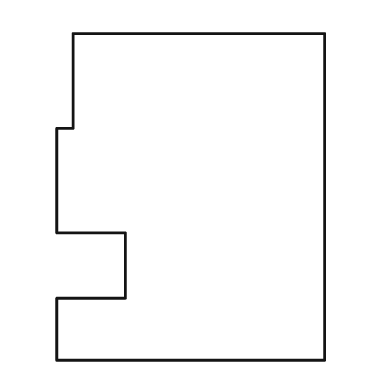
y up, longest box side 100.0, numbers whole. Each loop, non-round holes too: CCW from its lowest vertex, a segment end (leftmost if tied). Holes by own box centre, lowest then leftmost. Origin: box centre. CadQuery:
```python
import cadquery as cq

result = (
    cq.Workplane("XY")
    .moveTo(-41.0, -50.0)
    .lineTo(41.0, -50.0)
    .lineTo(41.0, 50.0)
    .lineTo(-36.0, 50.0)
    .lineTo(-36.0, 21.0)
    .lineTo(-41.0, 21.0)
    .lineTo(-41.0, -11.0)
    .lineTo(-20.0, -11.0)
    .lineTo(-20.0, -31.0)
    .lineTo(-41.0, -31.0)
    .close()
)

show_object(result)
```